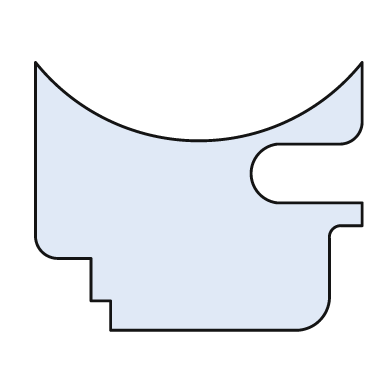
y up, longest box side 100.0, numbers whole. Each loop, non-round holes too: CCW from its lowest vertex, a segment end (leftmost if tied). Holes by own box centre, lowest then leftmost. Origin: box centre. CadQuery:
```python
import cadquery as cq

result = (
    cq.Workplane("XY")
    .moveTo(-27.0, -41.0)
    .lineTo(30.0, -41.0)
    .threePointArc((37.0, -38.0), (40.0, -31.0))
    .lineTo(40.0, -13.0)
    .threePointArc((41.0, -10.0), (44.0, -9.0))
    .lineTo(50.0, -9.0)
    .lineTo(50.0, -2.0)
    .lineTo(24.0, -2.0)
    .threePointArc((16.0, 7.0), (24.0, 16.0))
    .lineTo(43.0, 16.0)
    .threePointArc((48.0, 18.0), (50.0, 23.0))
    .lineTo(50.0, 41.0)
    .threePointArc((0.0, 17.0), (-50.0, 41.0))
    .lineTo(-50.0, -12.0)
    .threePointArc((-48.0, -17.0), (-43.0, -19.0))
    .lineTo(-33.0, -19.0)
    .lineTo(-33.0, -32.0)
    .lineTo(-27.0, -32.0)
    .close()
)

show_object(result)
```